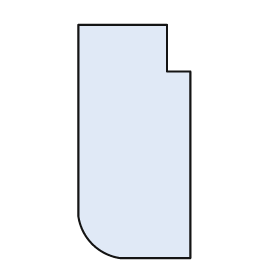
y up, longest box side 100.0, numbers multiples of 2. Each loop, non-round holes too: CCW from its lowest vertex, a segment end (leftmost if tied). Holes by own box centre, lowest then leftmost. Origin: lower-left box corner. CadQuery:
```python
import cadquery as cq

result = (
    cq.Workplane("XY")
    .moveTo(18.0, 0.0)
    .lineTo(48.0, 0.0)
    .lineTo(48.0, 80.0)
    .lineTo(38.0, 80.0)
    .lineTo(38.0, 100.0)
    .lineTo(0.0, 100.0)
    .lineTo(0.0, 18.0)
    .threePointArc((6.0, 6.0), (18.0, 0.0))
    .close()
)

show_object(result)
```